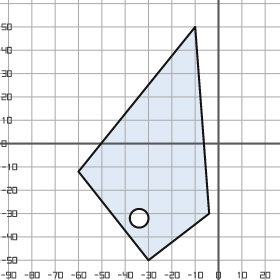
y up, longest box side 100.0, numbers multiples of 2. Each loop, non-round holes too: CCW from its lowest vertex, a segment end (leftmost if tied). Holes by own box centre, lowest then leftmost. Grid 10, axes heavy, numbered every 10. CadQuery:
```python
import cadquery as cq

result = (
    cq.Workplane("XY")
    .moveTo(-30.0, -50.0)
    .lineTo(-4.0, -30.0)
    .lineTo(-10.0, 50.0)
    .lineTo(-60.0, -12.0)
    .close()
    .moveTo(-34.0, -32.0)
    .circle(4.0)
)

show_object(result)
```